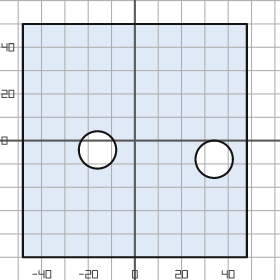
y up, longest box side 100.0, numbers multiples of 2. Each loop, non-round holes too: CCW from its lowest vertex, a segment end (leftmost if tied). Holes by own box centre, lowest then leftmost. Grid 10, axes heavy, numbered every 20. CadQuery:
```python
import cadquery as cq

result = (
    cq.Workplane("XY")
    .moveTo(-48.0, -50.0)
    .lineTo(48.0, -50.0)
    .lineTo(48.0, 50.0)
    .lineTo(-48.0, 50.0)
    .close()
    .moveTo(34.0, -8.0)
    .circle(8.0)
    .moveTo(-16.0, -4.0)
    .circle(8.0)
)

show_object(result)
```